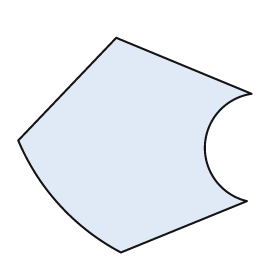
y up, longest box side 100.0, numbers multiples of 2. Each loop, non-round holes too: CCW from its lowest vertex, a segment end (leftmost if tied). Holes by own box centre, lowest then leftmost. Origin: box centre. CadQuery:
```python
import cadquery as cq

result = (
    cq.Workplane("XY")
    .moveTo(-6.0, -46.0)
    .lineTo(48.0, -24.0)
    .threePointArc((30.0, 0.0), (50.0, 22.0))
    .lineTo(-8.0, 46.0)
    .lineTo(-50.0, 2.0)
    .threePointArc((-32.0, -26.0), (-6.0, -46.0))
    .close()
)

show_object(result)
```